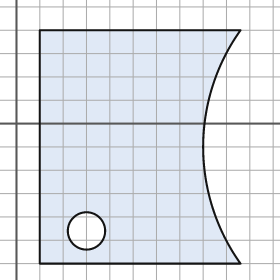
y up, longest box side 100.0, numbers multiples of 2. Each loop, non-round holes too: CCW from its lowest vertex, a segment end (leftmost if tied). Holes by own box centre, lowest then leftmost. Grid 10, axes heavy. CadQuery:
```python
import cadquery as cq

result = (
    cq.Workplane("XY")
    .moveTo(10.0, -60.0)
    .lineTo(96.0, -60.0)
    .threePointArc((80.0, -10.0), (96.0, 40.0))
    .lineTo(10.0, 40.0)
    .close()
    .moveTo(30.0, -46.0)
    .circle(8.0)
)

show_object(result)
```